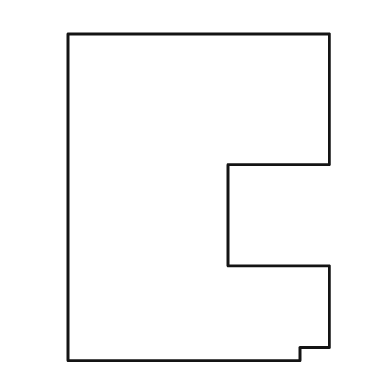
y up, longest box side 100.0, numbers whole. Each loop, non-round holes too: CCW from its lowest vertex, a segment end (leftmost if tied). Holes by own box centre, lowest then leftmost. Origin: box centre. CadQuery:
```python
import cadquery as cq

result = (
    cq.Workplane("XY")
    .moveTo(-40.0, -50.0)
    .lineTo(31.0, -50.0)
    .lineTo(31.0, -46.0)
    .lineTo(40.0, -46.0)
    .lineTo(40.0, -21.0)
    .lineTo(9.0, -21.0)
    .lineTo(9.0, 10.0)
    .lineTo(40.0, 10.0)
    .lineTo(40.0, 50.0)
    .lineTo(-40.0, 50.0)
    .close()
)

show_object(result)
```